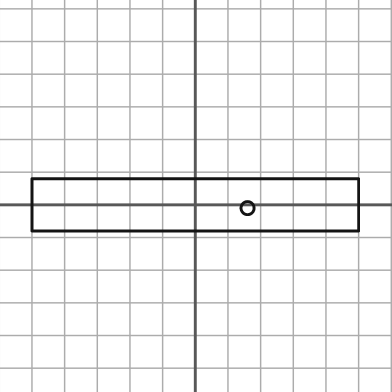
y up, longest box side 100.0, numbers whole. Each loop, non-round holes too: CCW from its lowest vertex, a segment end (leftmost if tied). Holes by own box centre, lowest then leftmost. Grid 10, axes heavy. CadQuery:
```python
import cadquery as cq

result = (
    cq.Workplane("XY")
    .moveTo(-50.0, -8.0)
    .lineTo(50.0, -8.0)
    .lineTo(50.0, 8.0)
    .lineTo(-50.0, 8.0)
    .close()
    .moveTo(16.0, -1.0)
    .circle(2.0)
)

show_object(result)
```